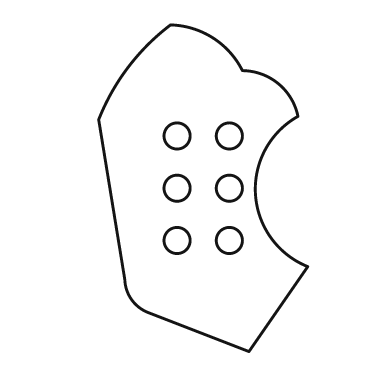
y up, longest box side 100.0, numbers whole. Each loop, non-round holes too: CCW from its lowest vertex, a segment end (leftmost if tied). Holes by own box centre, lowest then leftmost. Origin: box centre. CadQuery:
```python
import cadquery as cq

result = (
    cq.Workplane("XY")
    .moveTo(14.0, -50.0)
    .lineTo(32.0, -24.0)
    .threePointArc((16.0, -2.0), (29.0, 22.0))
    .threePointArc((23.0, 32.0), (12.0, 36.0))
    .threePointArc((3.0, 46.0), (-10.0, 50.0))
    .threePointArc((-23.0, 37.0), (-32.0, 21.0))
    .lineTo(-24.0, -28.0)
    .threePointArc((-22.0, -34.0), (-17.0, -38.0))
    .close()
    .moveTo(-8.0, -16.0)
    .circle(4.0)
    .moveTo(8.0, -16.0)
    .circle(4.0)
    .moveTo(-8.0, 0.0)
    .circle(4.0)
    .moveTo(8.0, 0.0)
    .circle(4.0)
    .moveTo(-8.0, 16.0)
    .circle(4.0)
    .moveTo(8.0, 16.0)
    .circle(4.0)
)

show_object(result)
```